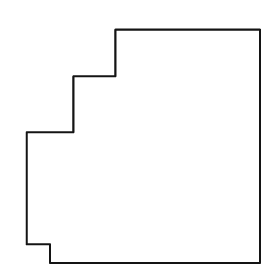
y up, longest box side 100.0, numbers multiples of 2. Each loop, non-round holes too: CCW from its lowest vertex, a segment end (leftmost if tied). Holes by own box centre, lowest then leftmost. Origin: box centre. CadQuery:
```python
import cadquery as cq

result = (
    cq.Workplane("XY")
    .moveTo(-40.0, -50.0)
    .lineTo(50.0, -50.0)
    .lineTo(50.0, 50.0)
    .lineTo(-12.0, 50.0)
    .lineTo(-12.0, 30.0)
    .lineTo(-30.0, 30.0)
    .lineTo(-30.0, 6.0)
    .lineTo(-50.0, 6.0)
    .lineTo(-50.0, -42.0)
    .lineTo(-40.0, -42.0)
    .close()
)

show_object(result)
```